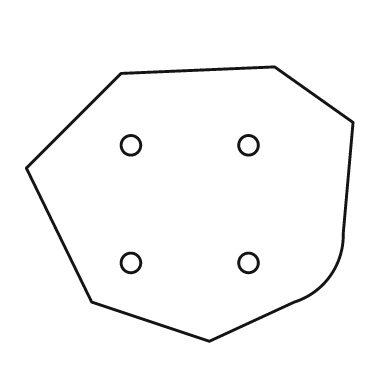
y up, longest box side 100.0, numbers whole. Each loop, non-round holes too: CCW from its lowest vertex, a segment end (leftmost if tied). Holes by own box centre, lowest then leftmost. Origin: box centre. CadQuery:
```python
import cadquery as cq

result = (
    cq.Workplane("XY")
    .moveTo(6.0, -42.0)
    .lineTo(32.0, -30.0)
    .threePointArc((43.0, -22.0), (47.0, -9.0))
    .lineTo(50.0, 25.0)
    .lineTo(26.0, 42.0)
    .lineTo(-21.0, 40.0)
    .lineTo(-50.0, 11.0)
    .lineTo(-30.0, -30.0)
    .close()
    .moveTo(-18.0, -18.0)
    .circle(3.0)
    .moveTo(18.0, -18.0)
    .circle(3.0)
    .moveTo(-18.0, 18.0)
    .circle(3.0)
    .moveTo(18.0, 18.0)
    .circle(3.0)
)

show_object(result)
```